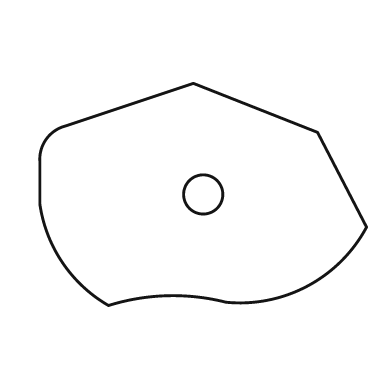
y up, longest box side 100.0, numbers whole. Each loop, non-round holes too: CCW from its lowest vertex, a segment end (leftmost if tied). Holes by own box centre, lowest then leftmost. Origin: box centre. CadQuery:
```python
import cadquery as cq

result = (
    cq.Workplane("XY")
    .moveTo(-29.0, -34.0)
    .threePointArc((-11.0, -31.0), (7.0, -33.0))
    .threePointArc((32.0, -28.0), (50.0, -10.0))
    .lineTo(35.0, 19.0)
    .lineTo(-3.0, 34.0)
    .lineTo(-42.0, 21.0)
    .threePointArc((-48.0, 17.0), (-50.0, 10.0))
    .lineTo(-50.0, -3.0)
    .threePointArc((-43.0, -21.0), (-29.0, -34.0))
    .close()
    .moveTo(0.0, 0.0)
    .circle(6.0)
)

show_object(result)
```